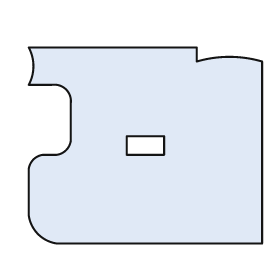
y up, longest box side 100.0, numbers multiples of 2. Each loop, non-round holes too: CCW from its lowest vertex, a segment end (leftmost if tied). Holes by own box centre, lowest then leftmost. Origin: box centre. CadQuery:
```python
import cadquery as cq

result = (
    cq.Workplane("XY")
    .moveTo(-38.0, -42.0)
    .lineTo(50.0, -42.0)
    .lineTo(50.0, 36.0)
    .threePointArc((36.0, 38.0), (22.0, 36.0))
    .lineTo(22.0, 42.0)
    .lineTo(-50.0, 42.0)
    .threePointArc((-48.0, 34.0), (-50.0, 26.0))
    .lineTo(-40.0, 26.0)
    .threePointArc((-34.0, 24.0), (-32.0, 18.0))
    .lineTo(-32.0, 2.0)
    .threePointArc((-34.0, -2.0), (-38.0, -4.0))
    .lineTo(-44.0, -4.0)
    .threePointArc((-48.0, -6.0), (-50.0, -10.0))
    .lineTo(-50.0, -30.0)
    .threePointArc((-46.0, -38.0), (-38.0, -42.0))
    .close()
    .moveTo(-8.0, -4.0)
    .lineTo(8.0, -4.0)
    .lineTo(8.0, 4.0)
    .lineTo(-8.0, 4.0)
    .close()
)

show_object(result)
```